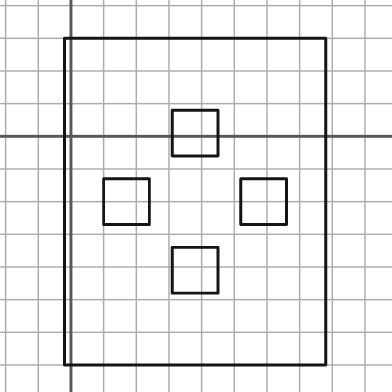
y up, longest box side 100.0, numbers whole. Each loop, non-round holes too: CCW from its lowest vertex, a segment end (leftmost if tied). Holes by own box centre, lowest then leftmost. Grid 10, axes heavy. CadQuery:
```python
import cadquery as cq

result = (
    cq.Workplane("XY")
    .moveTo(-2.0, -70.0)
    .lineTo(78.0, -70.0)
    .lineTo(78.0, 30.0)
    .lineTo(-2.0, 30.0)
    .close()
    .moveTo(31.0, -48.0)
    .lineTo(45.0, -48.0)
    .lineTo(45.0, -34.0)
    .lineTo(31.0, -34.0)
    .close()
    .moveTo(10.0, -27.0)
    .lineTo(24.0, -27.0)
    .lineTo(24.0, -13.0)
    .lineTo(10.0, -13.0)
    .close()
    .moveTo(52.0, -27.0)
    .lineTo(66.0, -27.0)
    .lineTo(66.0, -13.0)
    .lineTo(52.0, -13.0)
    .close()
    .moveTo(31.0, -6.0)
    .lineTo(45.0, -6.0)
    .lineTo(45.0, 8.0)
    .lineTo(31.0, 8.0)
    .close()
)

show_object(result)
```